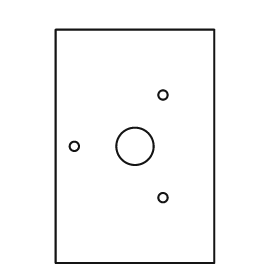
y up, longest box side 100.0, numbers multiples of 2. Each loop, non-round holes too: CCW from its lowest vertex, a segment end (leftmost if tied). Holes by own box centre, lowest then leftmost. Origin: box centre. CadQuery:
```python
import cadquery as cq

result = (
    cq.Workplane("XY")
    .moveTo(-34.0, -50.0)
    .lineTo(34.0, -50.0)
    .lineTo(34.0, 50.0)
    .lineTo(-34.0, 50.0)
    .close()
    .moveTo(12.0, -22.0)
    .circle(2.0)
    .moveTo(-26.0, 0.0)
    .circle(2.0)
    .moveTo(0.0, 0.0)
    .circle(8.0)
    .moveTo(12.0, 22.0)
    .circle(2.0)
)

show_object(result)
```